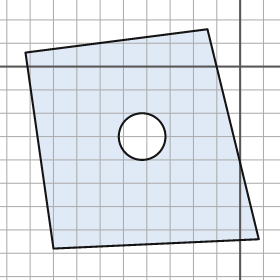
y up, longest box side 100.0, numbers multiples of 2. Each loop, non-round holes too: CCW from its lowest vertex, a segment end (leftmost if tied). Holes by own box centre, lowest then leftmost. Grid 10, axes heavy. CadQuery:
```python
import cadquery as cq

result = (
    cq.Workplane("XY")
    .moveTo(-80.0, -78.0)
    .lineTo(8.0, -74.0)
    .lineTo(-14.0, 16.0)
    .lineTo(-92.0, 6.0)
    .close()
    .moveTo(-42.0, -30.0)
    .circle(10.0)
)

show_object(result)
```